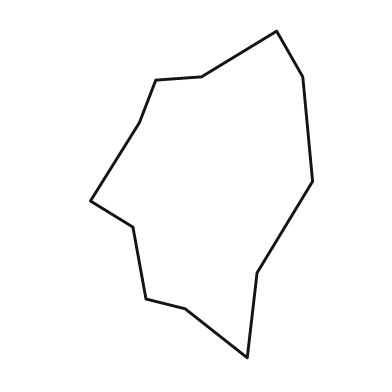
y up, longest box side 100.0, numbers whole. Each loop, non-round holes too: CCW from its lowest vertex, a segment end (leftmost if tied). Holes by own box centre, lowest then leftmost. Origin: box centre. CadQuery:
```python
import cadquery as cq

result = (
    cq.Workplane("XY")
    .moveTo(14.0, -50.0)
    .lineTo(17.0, -24.0)
    .lineTo(34.0, 4.0)
    .lineTo(31.0, 36.0)
    .lineTo(23.0, 50.0)
    .lineTo(0.0, 36.0)
    .lineTo(-14.0, 35.0)
    .lineTo(-19.0, 22.0)
    .lineTo(-34.0, -2.0)
    .lineTo(-21.0, -10.0)
    .lineTo(-17.0, -32.0)
    .lineTo(-5.0, -35.0)
    .close()
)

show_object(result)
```